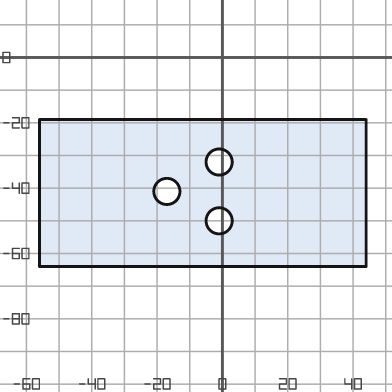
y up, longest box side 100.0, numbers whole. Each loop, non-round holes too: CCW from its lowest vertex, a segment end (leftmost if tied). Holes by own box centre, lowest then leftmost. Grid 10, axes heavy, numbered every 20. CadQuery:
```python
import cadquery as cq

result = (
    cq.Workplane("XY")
    .moveTo(-56.0, -64.0)
    .lineTo(44.0, -64.0)
    .lineTo(44.0, -19.0)
    .lineTo(-56.0, -19.0)
    .close()
    .moveTo(-1.0, -50.0)
    .circle(4.0)
    .moveTo(-17.0, -41.0)
    .circle(4.0)
    .moveTo(-1.0, -32.0)
    .circle(4.0)
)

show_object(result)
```